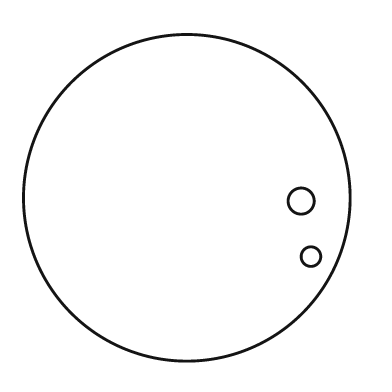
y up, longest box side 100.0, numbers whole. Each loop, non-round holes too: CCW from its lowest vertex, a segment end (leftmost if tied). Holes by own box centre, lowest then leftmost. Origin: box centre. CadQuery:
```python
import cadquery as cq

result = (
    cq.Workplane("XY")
    .moveTo(0.0, 0.0)
    .circle(50.0)
    .moveTo(38.0, -18.0)
    .circle(3.0)
    .moveTo(35.0, -1.0)
    .circle(4.0)
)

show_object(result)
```